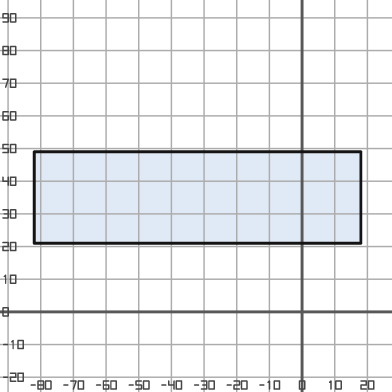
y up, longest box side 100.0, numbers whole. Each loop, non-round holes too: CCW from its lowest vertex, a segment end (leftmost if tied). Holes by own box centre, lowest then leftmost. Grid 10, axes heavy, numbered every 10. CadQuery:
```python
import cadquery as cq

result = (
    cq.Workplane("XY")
    .moveTo(-82.0, 21.0)
    .lineTo(18.0, 21.0)
    .lineTo(18.0, 49.0)
    .lineTo(-82.0, 49.0)
    .close()
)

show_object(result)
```